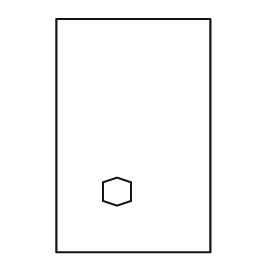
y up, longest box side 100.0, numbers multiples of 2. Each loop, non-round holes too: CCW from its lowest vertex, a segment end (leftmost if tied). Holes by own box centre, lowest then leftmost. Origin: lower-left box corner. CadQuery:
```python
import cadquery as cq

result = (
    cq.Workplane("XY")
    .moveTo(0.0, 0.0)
    .lineTo(66.0, 0.0)
    .lineTo(66.0, 100.0)
    .lineTo(0.0, 100.0)
    .close()
    .moveTo(26.0, 20.0)
    .lineTo(32.0, 22.0)
    .lineTo(32.0, 30.0)
    .lineTo(26.0, 32.0)
    .lineTo(20.0, 30.0)
    .lineTo(20.0, 22.0)
    .close()
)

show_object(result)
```